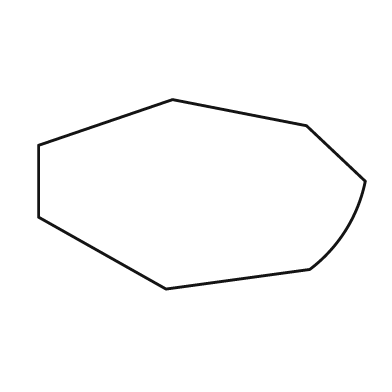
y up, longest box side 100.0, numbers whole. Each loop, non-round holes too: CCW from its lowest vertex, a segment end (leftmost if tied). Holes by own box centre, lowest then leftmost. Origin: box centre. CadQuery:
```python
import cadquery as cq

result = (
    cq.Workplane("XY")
    .moveTo(-11.0, -29.0)
    .lineTo(33.0, -23.0)
    .threePointArc((44.0, -11.0), (50.0, 4.0))
    .lineTo(32.0, 21.0)
    .lineTo(-9.0, 29.0)
    .lineTo(-50.0, 15.0)
    .lineTo(-50.0, -7.0)
    .close()
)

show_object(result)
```